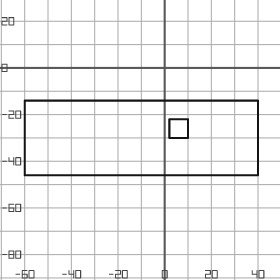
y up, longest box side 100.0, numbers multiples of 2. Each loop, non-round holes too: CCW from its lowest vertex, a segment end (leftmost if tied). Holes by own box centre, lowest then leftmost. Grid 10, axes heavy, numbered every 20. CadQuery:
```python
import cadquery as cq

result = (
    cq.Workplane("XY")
    .moveTo(-60.0, -46.0)
    .lineTo(40.0, -46.0)
    .lineTo(40.0, -14.0)
    .lineTo(-60.0, -14.0)
    .close()
    .moveTo(2.0, -30.0)
    .lineTo(10.0, -30.0)
    .lineTo(10.0, -22.0)
    .lineTo(2.0, -22.0)
    .close()
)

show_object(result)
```